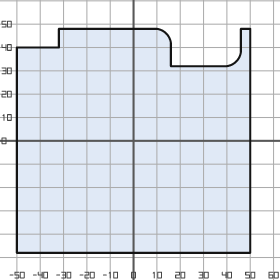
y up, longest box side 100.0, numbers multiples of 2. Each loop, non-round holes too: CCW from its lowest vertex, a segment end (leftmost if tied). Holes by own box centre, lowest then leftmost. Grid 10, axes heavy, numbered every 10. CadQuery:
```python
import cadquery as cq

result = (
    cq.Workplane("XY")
    .moveTo(-50.0, -48.0)
    .lineTo(50.0, -48.0)
    .lineTo(50.0, 48.0)
    .lineTo(46.0, 48.0)
    .lineTo(46.0, 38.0)
    .threePointArc((44.0, 34.0), (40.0, 32.0))
    .lineTo(16.0, 32.0)
    .lineTo(16.0, 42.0)
    .threePointArc((14.0, 46.0), (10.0, 48.0))
    .lineTo(-32.0, 48.0)
    .lineTo(-32.0, 40.0)
    .lineTo(-50.0, 40.0)
    .close()
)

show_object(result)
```